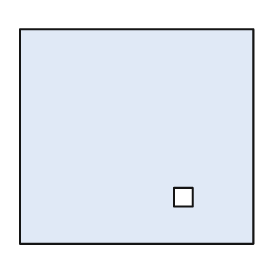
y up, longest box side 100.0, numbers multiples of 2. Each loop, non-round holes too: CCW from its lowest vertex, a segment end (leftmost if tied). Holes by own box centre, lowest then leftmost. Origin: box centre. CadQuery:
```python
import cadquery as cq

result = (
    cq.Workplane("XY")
    .moveTo(-50.0, -46.0)
    .lineTo(50.0, -46.0)
    .lineTo(50.0, 46.0)
    .lineTo(-50.0, 46.0)
    .close()
    .moveTo(16.0, -30.0)
    .lineTo(24.0, -30.0)
    .lineTo(24.0, -22.0)
    .lineTo(16.0, -22.0)
    .close()
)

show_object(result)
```